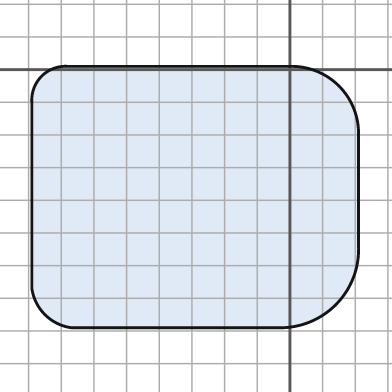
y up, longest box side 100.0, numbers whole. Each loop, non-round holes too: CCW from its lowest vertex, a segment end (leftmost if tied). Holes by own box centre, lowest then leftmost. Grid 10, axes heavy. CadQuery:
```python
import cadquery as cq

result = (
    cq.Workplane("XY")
    .moveTo(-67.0, -79.0)
    .lineTo(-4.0, -79.0)
    .threePointArc((14.0, -72.0), (21.0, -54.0))
    .lineTo(21.0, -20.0)
    .threePointArc((15.0, -5.0), (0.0, 1.0))
    .lineTo(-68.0, 1.0)
    .threePointArc((-76.0, -2.0), (-79.0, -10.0))
    .lineTo(-79.0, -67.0)
    .threePointArc((-75.0, -75.0), (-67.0, -79.0))
    .close()
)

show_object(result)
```